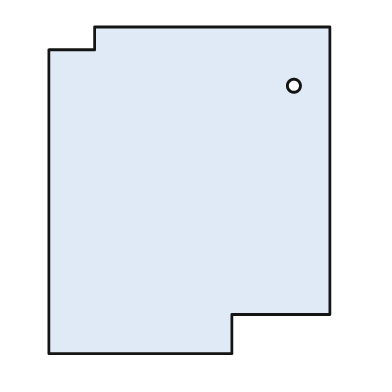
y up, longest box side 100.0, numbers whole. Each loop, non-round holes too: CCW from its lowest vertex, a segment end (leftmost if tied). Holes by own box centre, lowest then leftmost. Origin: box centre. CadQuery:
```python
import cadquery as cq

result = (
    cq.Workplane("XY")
    .moveTo(-43.0, -50.0)
    .lineTo(13.0, -50.0)
    .lineTo(13.0, -38.0)
    .lineTo(43.0, -38.0)
    .lineTo(43.0, 50.0)
    .lineTo(-29.0, 50.0)
    .lineTo(-29.0, 43.0)
    .lineTo(-43.0, 43.0)
    .close()
    .moveTo(32.0, 32.0)
    .circle(2.0)
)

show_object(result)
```